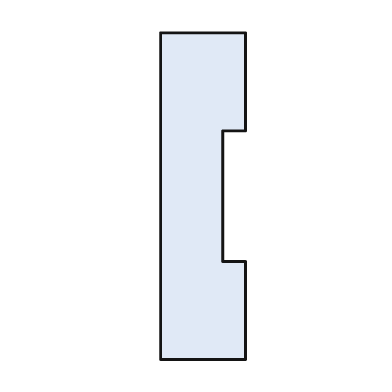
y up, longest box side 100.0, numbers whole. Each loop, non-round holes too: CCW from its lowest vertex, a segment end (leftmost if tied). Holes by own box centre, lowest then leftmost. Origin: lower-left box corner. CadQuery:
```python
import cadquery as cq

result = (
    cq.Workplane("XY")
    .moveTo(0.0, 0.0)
    .lineTo(26.0, 0.0)
    .lineTo(26.0, 30.0)
    .lineTo(19.0, 30.0)
    .lineTo(19.0, 70.0)
    .lineTo(26.0, 70.0)
    .lineTo(26.0, 100.0)
    .lineTo(0.0, 100.0)
    .close()
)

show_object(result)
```